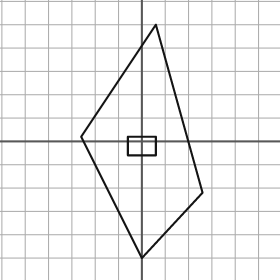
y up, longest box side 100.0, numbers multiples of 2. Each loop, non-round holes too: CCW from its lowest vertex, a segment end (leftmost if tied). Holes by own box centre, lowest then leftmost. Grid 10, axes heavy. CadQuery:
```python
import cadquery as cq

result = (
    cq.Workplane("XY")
    .moveTo(0.0, -50.0)
    .lineTo(26.0, -22.0)
    .lineTo(6.0, 50.0)
    .lineTo(-26.0, 2.0)
    .close()
    .moveTo(-6.0, -6.0)
    .lineTo(6.0, -6.0)
    .lineTo(6.0, 2.0)
    .lineTo(-6.0, 2.0)
    .close()
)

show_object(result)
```